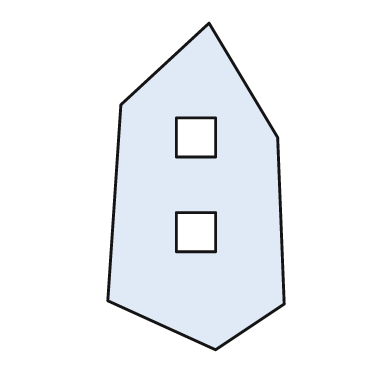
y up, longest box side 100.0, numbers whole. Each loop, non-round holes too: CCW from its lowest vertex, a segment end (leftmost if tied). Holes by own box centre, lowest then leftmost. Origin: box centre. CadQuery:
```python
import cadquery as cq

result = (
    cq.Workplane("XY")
    .moveTo(6.0, -50.0)
    .lineTo(27.0, -36.0)
    .lineTo(25.0, 15.0)
    .lineTo(4.0, 50.0)
    .lineTo(-23.0, 25.0)
    .lineTo(-27.0, -35.0)
    .close()
    .moveTo(-6.0, -20.0)
    .lineTo(6.0, -20.0)
    .lineTo(6.0, -8.0)
    .lineTo(-6.0, -8.0)
    .close()
    .moveTo(-6.0, 9.0)
    .lineTo(6.0, 9.0)
    .lineTo(6.0, 21.0)
    .lineTo(-6.0, 21.0)
    .close()
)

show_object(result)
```